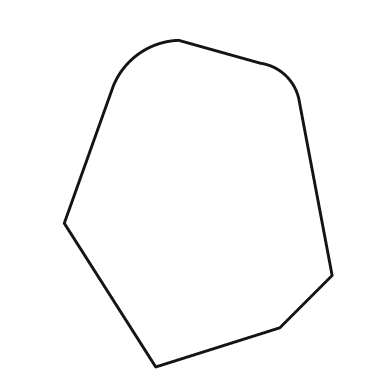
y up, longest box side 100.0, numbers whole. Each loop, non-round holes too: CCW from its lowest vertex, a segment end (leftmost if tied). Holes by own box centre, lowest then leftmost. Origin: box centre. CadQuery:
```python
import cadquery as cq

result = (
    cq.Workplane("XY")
    .moveTo(-13.0, -50.0)
    .lineTo(25.0, -38.0)
    .lineTo(41.0, -22.0)
    .lineTo(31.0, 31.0)
    .threePointArc((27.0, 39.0), (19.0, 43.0))
    .lineTo(-6.0, 50.0)
    .threePointArc((-18.0, 46.0), (-26.0, 36.0))
    .lineTo(-41.0, -6.0)
    .close()
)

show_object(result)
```